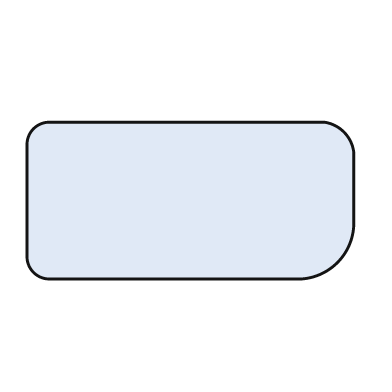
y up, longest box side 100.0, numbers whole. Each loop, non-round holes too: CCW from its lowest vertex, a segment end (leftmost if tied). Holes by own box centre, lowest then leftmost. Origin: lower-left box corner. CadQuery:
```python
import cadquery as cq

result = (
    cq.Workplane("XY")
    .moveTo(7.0, 0.0)
    .lineTo(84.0, 0.0)
    .threePointArc((95.0, 5.0), (100.0, 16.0))
    .lineTo(100.0, 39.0)
    .threePointArc((97.0, 45.0), (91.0, 48.0))
    .lineTo(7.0, 48.0)
    .threePointArc((2.0, 46.0), (0.0, 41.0))
    .lineTo(0.0, 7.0)
    .threePointArc((2.0, 2.0), (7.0, 0.0))
    .close()
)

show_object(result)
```